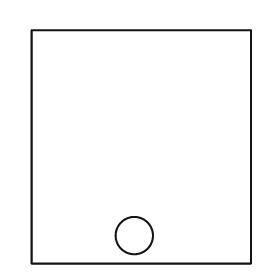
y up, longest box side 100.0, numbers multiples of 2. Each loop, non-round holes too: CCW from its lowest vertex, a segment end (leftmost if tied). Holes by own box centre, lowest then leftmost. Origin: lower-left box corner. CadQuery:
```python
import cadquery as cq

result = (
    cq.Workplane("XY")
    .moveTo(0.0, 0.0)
    .lineTo(94.0, 0.0)
    .lineTo(94.0, 100.0)
    .lineTo(0.0, 100.0)
    .close()
    .moveTo(44.0, 12.0)
    .circle(8.0)
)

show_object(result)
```